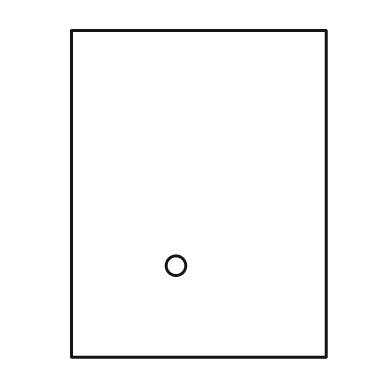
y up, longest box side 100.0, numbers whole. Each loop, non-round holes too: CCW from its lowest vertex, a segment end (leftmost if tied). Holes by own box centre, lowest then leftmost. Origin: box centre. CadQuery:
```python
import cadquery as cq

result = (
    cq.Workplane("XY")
    .moveTo(-39.0, -50.0)
    .lineTo(39.0, -50.0)
    .lineTo(39.0, 50.0)
    .lineTo(-39.0, 50.0)
    .close()
    .moveTo(-7.0, -22.0)
    .circle(3.0)
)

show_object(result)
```